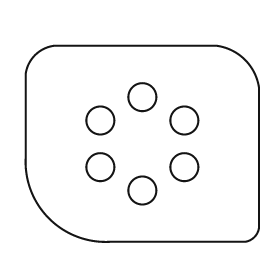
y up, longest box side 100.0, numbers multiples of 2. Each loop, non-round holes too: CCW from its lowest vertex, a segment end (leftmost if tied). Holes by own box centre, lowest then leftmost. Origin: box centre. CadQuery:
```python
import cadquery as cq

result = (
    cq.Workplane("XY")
    .moveTo(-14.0, -42.0)
    .lineTo(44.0, -42.0)
    .threePointArc((48.0, -40.0), (50.0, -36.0))
    .lineTo(50.0, 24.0)
    .threePointArc((44.0, 36.0), (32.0, 42.0))
    .lineTo(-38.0, 42.0)
    .threePointArc((-46.0, 38.0), (-50.0, 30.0))
    .lineTo(-50.0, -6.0)
    .threePointArc((-40.0, -32.0), (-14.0, -42.0))
    .close()
    .moveTo(0.0, -20.0)
    .circle(6.0)
    .moveTo(-18.0, -10.0)
    .circle(6.0)
    .moveTo(18.0, -10.0)
    .circle(6.0)
    .moveTo(-18.0, 10.0)
    .circle(6.0)
    .moveTo(18.0, 10.0)
    .circle(6.0)
    .moveTo(0.0, 20.0)
    .circle(6.0)
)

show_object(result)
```